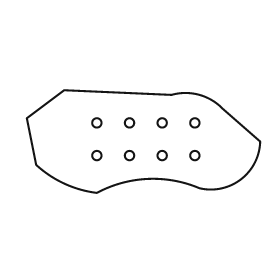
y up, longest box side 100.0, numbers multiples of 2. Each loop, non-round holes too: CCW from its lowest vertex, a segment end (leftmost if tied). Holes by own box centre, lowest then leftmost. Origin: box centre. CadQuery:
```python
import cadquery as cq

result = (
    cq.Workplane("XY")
    .moveTo(-20.0, -22.0)
    .threePointArc((2.0, -16.0), (24.0, -20.0))
    .threePointArc((42.0, -16.0), (50.0, 0.0))
    .lineTo(34.0, 14.0)
    .threePointArc((24.0, 20.0), (12.0, 20.0))
    .lineTo(-34.0, 22.0)
    .lineTo(-50.0, 10.0)
    .lineTo(-46.0, -10.0)
    .threePointArc((-34.0, -18.0), (-20.0, -22.0))
    .close()
    .moveTo(-20.0, -6.0)
    .circle(2.0)
    .moveTo(-6.0, -6.0)
    .circle(2.0)
    .moveTo(8.0, -6.0)
    .circle(2.0)
    .moveTo(22.0, -6.0)
    .circle(2.0)
    .moveTo(-20.0, 8.0)
    .circle(2.0)
    .moveTo(-6.0, 8.0)
    .circle(2.0)
    .moveTo(8.0, 8.0)
    .circle(2.0)
    .moveTo(22.0, 8.0)
    .circle(2.0)
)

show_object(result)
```